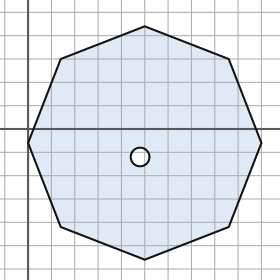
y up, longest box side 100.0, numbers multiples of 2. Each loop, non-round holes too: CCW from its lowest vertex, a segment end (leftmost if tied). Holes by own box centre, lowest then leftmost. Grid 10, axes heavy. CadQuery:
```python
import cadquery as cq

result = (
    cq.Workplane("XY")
    .moveTo(50.0, -56.0)
    .lineTo(86.0, -42.0)
    .lineTo(100.0, -6.0)
    .lineTo(86.0, 30.0)
    .lineTo(50.0, 44.0)
    .lineTo(14.0, 30.0)
    .lineTo(0.0, -6.0)
    .lineTo(14.0, -42.0)
    .close()
    .moveTo(48.0, -12.0)
    .circle(4.0)
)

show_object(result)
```